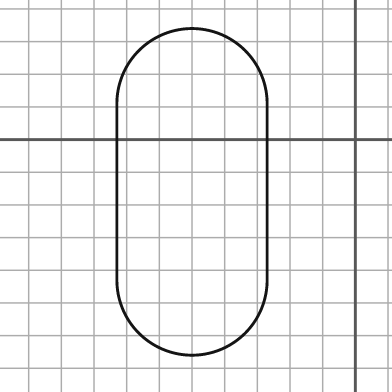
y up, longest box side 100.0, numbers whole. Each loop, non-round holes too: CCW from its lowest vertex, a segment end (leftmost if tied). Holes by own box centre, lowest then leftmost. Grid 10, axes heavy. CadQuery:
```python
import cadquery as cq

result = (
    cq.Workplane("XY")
    .moveTo(-73.0, -43.0)
    .threePointArc((-50.0, -66.0), (-27.0, -43.0))
    .lineTo(-27.0, 11.0)
    .threePointArc((-50.0, 34.0), (-73.0, 11.0))
    .close()
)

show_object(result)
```